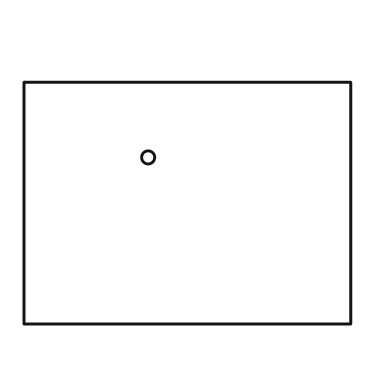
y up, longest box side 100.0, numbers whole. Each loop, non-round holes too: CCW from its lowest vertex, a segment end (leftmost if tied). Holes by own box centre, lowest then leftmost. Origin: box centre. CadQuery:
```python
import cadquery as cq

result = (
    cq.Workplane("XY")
    .moveTo(-50.0, -37.0)
    .lineTo(50.0, -37.0)
    .lineTo(50.0, 37.0)
    .lineTo(-50.0, 37.0)
    .close()
    .moveTo(-12.0, 14.0)
    .circle(2.0)
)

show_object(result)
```